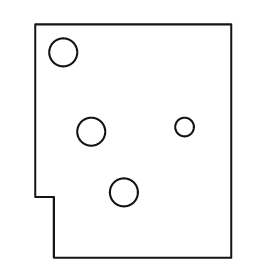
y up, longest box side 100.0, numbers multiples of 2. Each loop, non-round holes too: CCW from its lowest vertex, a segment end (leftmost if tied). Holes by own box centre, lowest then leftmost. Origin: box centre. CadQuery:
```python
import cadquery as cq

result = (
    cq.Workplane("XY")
    .moveTo(-34.0, -50.0)
    .lineTo(42.0, -50.0)
    .lineTo(42.0, 50.0)
    .lineTo(-42.0, 50.0)
    .lineTo(-42.0, -24.0)
    .lineTo(-34.0, -24.0)
    .close()
    .moveTo(-4.0, -22.0)
    .circle(6.0)
    .moveTo(-18.0, 4.0)
    .circle(6.0)
    .moveTo(22.0, 6.0)
    .circle(4.0)
    .moveTo(-30.0, 38.0)
    .circle(6.0)
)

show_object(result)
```